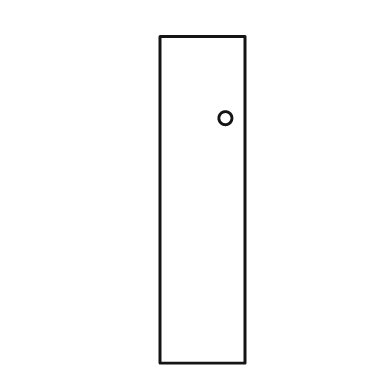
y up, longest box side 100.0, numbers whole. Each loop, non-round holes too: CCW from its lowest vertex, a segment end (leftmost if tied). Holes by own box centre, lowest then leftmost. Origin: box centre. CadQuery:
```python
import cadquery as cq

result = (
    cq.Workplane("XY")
    .moveTo(-13.0, -50.0)
    .lineTo(13.0, -50.0)
    .lineTo(13.0, 50.0)
    .lineTo(-13.0, 50.0)
    .close()
    .moveTo(7.0, 25.0)
    .circle(2.0)
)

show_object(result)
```